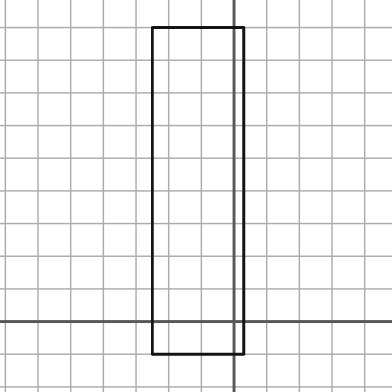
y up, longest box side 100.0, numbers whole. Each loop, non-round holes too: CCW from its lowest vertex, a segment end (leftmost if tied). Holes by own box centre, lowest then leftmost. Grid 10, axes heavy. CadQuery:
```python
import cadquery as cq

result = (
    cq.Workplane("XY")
    .moveTo(-25.0, -10.0)
    .lineTo(3.0, -10.0)
    .lineTo(3.0, 90.0)
    .lineTo(-25.0, 90.0)
    .close()
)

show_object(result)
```